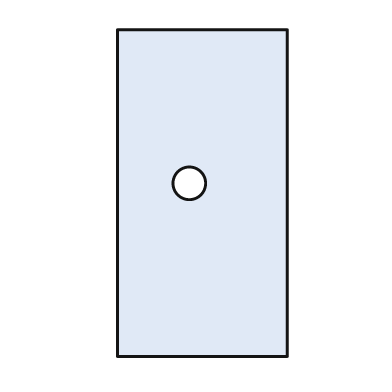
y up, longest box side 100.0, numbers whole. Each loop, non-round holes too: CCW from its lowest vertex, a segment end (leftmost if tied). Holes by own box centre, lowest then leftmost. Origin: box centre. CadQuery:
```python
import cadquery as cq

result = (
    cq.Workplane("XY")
    .moveTo(-26.0, -50.0)
    .lineTo(26.0, -50.0)
    .lineTo(26.0, 50.0)
    .lineTo(-26.0, 50.0)
    .close()
    .moveTo(-4.0, 3.0)
    .circle(5.0)
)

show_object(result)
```